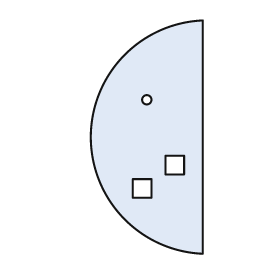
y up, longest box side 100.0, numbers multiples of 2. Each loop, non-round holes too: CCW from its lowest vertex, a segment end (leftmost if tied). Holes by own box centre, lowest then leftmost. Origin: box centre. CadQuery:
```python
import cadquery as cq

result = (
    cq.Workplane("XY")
    .moveTo(24.0, -50.0)
    .lineTo(24.0, 50.0)
    .threePointArc((-24.0, 0.0), (24.0, -50.0))
    .close()
    .moveTo(-6.0, -26.0)
    .lineTo(2.0, -26.0)
    .lineTo(2.0, -18.0)
    .lineTo(-6.0, -18.0)
    .close()
    .moveTo(8.0, -16.0)
    .lineTo(16.0, -16.0)
    .lineTo(16.0, -8.0)
    .lineTo(8.0, -8.0)
    .close()
    .moveTo(0.0, 16.0)
    .circle(2.0)
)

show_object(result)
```